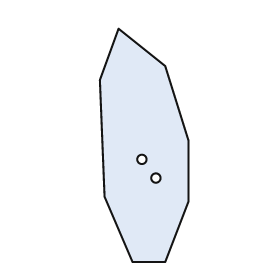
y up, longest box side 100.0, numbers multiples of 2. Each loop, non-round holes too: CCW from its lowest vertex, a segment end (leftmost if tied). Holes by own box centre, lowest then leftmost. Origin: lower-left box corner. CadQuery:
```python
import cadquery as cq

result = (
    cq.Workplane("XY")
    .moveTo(14.0, 0.0)
    .lineTo(28.0, 0.0)
    .lineTo(38.0, 26.0)
    .lineTo(38.0, 52.0)
    .lineTo(28.0, 84.0)
    .lineTo(8.0, 100.0)
    .lineTo(0.0, 78.0)
    .lineTo(2.0, 28.0)
    .close()
    .moveTo(24.0, 36.0)
    .circle(2.0)
    .moveTo(18.0, 44.0)
    .circle(2.0)
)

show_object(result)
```